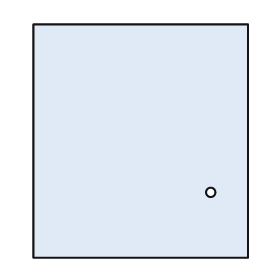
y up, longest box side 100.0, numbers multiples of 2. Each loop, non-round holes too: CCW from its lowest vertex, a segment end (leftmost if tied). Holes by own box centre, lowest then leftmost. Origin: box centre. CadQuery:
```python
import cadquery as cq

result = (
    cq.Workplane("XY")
    .moveTo(-46.0, -50.0)
    .lineTo(46.0, -50.0)
    .lineTo(46.0, 50.0)
    .lineTo(-46.0, 50.0)
    .close()
    .moveTo(30.0, -22.0)
    .circle(2.0)
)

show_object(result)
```